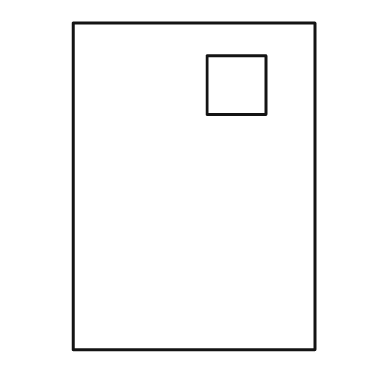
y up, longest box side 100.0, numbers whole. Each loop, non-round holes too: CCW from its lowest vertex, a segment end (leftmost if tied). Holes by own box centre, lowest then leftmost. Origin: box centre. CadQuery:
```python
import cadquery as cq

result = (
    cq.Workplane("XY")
    .moveTo(-37.0, -50.0)
    .lineTo(37.0, -50.0)
    .lineTo(37.0, 50.0)
    .lineTo(-37.0, 50.0)
    .close()
    .moveTo(4.0, 22.0)
    .lineTo(22.0, 22.0)
    .lineTo(22.0, 40.0)
    .lineTo(4.0, 40.0)
    .close()
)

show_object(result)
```